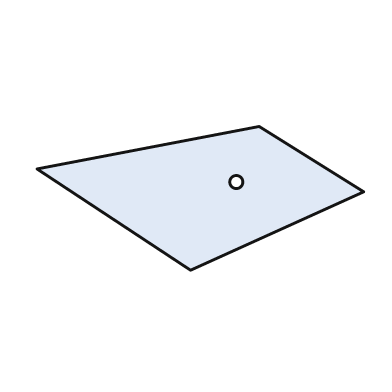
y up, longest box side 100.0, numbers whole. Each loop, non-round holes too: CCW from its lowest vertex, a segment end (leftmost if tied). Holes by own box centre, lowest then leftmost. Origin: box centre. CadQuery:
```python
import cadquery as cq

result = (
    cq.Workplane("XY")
    .moveTo(-3.0, -22.0)
    .lineTo(50.0, 2.0)
    .lineTo(18.0, 22.0)
    .lineTo(-50.0, 9.0)
    .close()
    .moveTo(11.0, 5.0)
    .circle(2.0)
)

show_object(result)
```